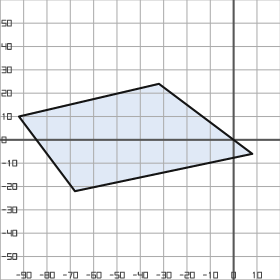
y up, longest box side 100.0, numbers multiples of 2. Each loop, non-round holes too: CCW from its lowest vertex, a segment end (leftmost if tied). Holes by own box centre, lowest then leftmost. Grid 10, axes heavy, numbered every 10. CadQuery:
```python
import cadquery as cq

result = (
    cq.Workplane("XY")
    .moveTo(-68.0, -22.0)
    .lineTo(8.0, -6.0)
    .lineTo(-32.0, 24.0)
    .lineTo(-92.0, 10.0)
    .close()
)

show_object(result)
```